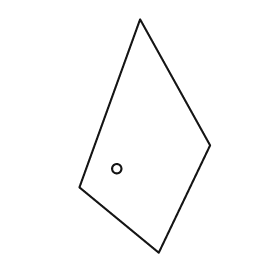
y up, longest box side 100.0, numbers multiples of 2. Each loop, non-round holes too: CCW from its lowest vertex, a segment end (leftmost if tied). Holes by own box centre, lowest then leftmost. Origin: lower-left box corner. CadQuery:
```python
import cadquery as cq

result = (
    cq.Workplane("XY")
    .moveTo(34.0, 0.0)
    .lineTo(56.0, 46.0)
    .lineTo(26.0, 100.0)
    .lineTo(0.0, 28.0)
    .close()
    .moveTo(16.0, 36.0)
    .circle(2.0)
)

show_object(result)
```